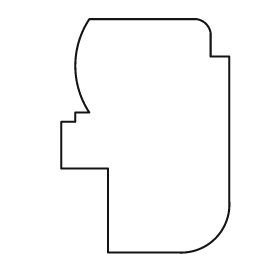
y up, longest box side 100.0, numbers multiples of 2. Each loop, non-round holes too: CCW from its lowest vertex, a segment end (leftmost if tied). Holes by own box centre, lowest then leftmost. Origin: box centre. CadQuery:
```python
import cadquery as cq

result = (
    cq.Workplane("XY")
    .moveTo(-16.0, -50.0)
    .lineTo(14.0, -50.0)
    .threePointArc((30.0, -44.0), (36.0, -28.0))
    .lineTo(36.0, 34.0)
    .lineTo(28.0, 34.0)
    .lineTo(28.0, 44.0)
    .threePointArc((26.0, 48.0), (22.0, 50.0))
    .lineTo(-24.0, 50.0)
    .threePointArc((-30.0, 30.0), (-24.0, 10.0))
    .lineTo(-30.0, 10.0)
    .lineTo(-30.0, 6.0)
    .lineTo(-36.0, 6.0)
    .lineTo(-36.0, -14.0)
    .lineTo(-16.0, -14.0)
    .close()
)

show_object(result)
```